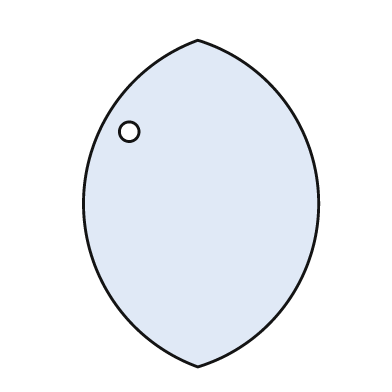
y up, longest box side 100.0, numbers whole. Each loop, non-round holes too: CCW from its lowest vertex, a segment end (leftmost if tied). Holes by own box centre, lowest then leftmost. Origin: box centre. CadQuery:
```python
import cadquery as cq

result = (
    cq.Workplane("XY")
    .moveTo(-1.0, -50.0)
    .threePointArc((36.0, 0.0), (-1.0, 50.0))
    .threePointArc((-36.0, 0.0), (-1.0, -50.0))
    .close()
    .moveTo(-22.0, 22.0)
    .circle(3.0)
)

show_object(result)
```